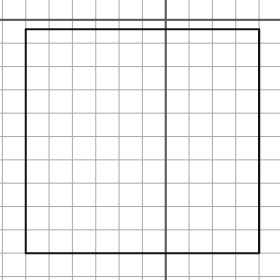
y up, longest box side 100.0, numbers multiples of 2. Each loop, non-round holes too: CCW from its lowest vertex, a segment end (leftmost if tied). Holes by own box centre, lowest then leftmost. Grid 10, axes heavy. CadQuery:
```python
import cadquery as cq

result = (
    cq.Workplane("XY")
    .moveTo(-60.0, -100.0)
    .lineTo(40.0, -100.0)
    .lineTo(40.0, -4.0)
    .lineTo(-60.0, -4.0)
    .close()
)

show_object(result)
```